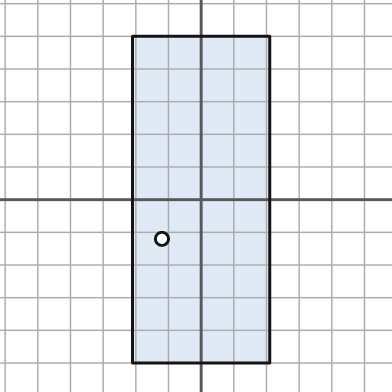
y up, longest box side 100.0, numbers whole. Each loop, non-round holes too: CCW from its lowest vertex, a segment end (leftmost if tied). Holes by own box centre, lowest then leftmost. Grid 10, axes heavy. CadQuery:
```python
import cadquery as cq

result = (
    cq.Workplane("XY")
    .moveTo(-21.0, -50.0)
    .lineTo(21.0, -50.0)
    .lineTo(21.0, 50.0)
    .lineTo(-21.0, 50.0)
    .close()
    .moveTo(-12.0, -12.0)
    .circle(2.0)
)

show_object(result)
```